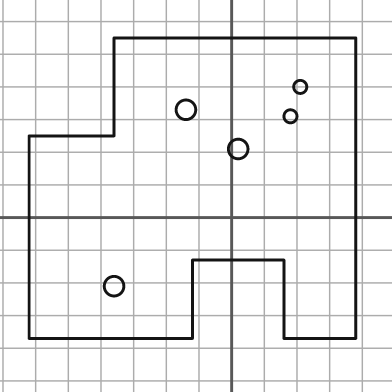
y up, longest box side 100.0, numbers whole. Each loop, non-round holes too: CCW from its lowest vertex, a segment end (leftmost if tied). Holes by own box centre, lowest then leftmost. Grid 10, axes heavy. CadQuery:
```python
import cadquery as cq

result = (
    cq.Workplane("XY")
    .moveTo(-62.0, -37.0)
    .lineTo(-12.0, -37.0)
    .lineTo(-12.0, -13.0)
    .lineTo(16.0, -13.0)
    .lineTo(16.0, -37.0)
    .lineTo(38.0, -37.0)
    .lineTo(38.0, 55.0)
    .lineTo(-36.0, 55.0)
    .lineTo(-36.0, 25.0)
    .lineTo(-62.0, 25.0)
    .close()
    .moveTo(-36.0, -21.0)
    .circle(3.0)
    .moveTo(2.0, 21.0)
    .circle(3.0)
    .moveTo(18.0, 31.0)
    .circle(2.0)
    .moveTo(-14.0, 33.0)
    .circle(3.0)
    .moveTo(21.0, 40.0)
    .circle(2.0)
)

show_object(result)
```